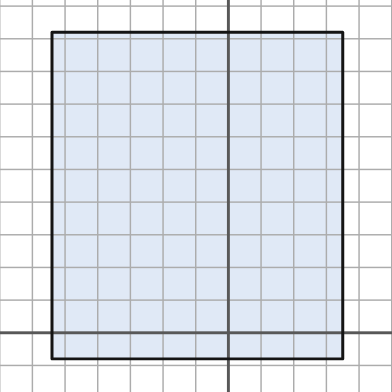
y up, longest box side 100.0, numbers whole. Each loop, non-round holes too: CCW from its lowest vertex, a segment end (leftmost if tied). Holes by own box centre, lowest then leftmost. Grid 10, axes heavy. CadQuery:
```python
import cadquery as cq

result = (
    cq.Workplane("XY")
    .moveTo(-54.0, -8.0)
    .lineTo(35.0, -8.0)
    .lineTo(35.0, 92.0)
    .lineTo(-54.0, 92.0)
    .close()
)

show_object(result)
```